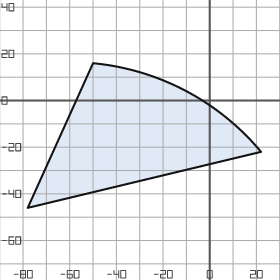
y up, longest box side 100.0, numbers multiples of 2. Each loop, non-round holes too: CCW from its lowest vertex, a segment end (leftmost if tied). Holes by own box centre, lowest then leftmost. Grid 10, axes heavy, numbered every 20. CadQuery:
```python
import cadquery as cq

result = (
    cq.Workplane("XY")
    .moveTo(-78.0, -46.0)
    .lineTo(22.0, -22.0)
    .threePointArc((-10.0, 4.0), (-50.0, 16.0))
    .close()
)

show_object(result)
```